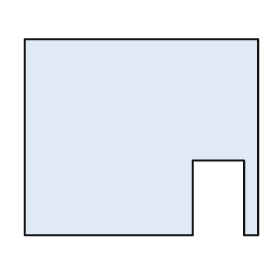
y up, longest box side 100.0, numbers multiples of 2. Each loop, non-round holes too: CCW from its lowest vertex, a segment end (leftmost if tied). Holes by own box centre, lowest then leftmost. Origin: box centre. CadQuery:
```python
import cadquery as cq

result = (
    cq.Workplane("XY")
    .moveTo(-50.0, -42.0)
    .lineTo(22.0, -42.0)
    .lineTo(22.0, -10.0)
    .lineTo(44.0, -10.0)
    .lineTo(44.0, -42.0)
    .lineTo(50.0, -42.0)
    .lineTo(50.0, 42.0)
    .lineTo(-50.0, 42.0)
    .close()
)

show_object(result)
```